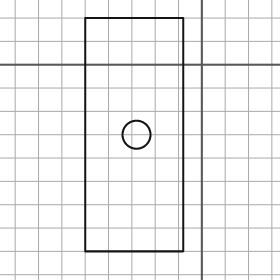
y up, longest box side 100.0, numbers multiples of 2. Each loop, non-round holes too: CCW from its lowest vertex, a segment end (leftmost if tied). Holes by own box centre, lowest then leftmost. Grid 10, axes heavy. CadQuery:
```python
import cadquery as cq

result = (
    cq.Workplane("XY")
    .moveTo(-50.0, -80.0)
    .lineTo(-8.0, -80.0)
    .lineTo(-8.0, 20.0)
    .lineTo(-50.0, 20.0)
    .close()
    .moveTo(-28.0, -30.0)
    .circle(6.0)
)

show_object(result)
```